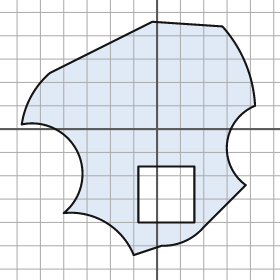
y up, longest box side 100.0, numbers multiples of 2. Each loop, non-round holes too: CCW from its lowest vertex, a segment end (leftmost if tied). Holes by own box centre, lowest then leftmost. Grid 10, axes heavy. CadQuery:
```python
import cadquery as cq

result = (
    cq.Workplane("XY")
    .moveTo(-10.0, -54.0)
    .lineTo(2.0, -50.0)
    .threePointArc((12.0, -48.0), (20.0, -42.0))
    .lineTo(38.0, -24.0)
    .threePointArc((30.0, -6.0), (42.0, 10.0))
    .threePointArc((38.0, 28.0), (28.0, 44.0))
    .lineTo(-2.0, 46.0)
    .lineTo(-46.0, 24.0)
    .threePointArc((-54.0, 14.0), (-58.0, 2.0))
    .threePointArc((-34.0, -10.0), (-40.0, -36.0))
    .threePointArc((-22.0, -40.0), (-10.0, -54.0))
    .close()
    .moveTo(-8.0, -40.0)
    .lineTo(16.0, -40.0)
    .lineTo(16.0, -16.0)
    .lineTo(-8.0, -16.0)
    .close()
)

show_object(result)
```